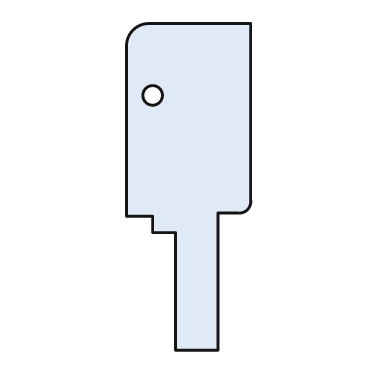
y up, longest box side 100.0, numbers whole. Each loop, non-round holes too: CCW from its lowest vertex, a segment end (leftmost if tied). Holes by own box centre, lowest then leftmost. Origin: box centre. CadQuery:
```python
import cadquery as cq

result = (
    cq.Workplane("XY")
    .moveTo(-4.0, -50.0)
    .lineTo(9.0, -50.0)
    .lineTo(9.0, -8.0)
    .lineTo(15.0, -8.0)
    .threePointArc((18.0, -7.0), (19.0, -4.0))
    .lineTo(19.0, 50.0)
    .lineTo(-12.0, 50.0)
    .threePointArc((-17.0, 48.0), (-19.0, 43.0))
    .lineTo(-19.0, -9.0)
    .lineTo(-11.0, -9.0)
    .lineTo(-11.0, -14.0)
    .lineTo(-4.0, -14.0)
    .close()
    .moveTo(-11.0, 28.0)
    .circle(3.0)
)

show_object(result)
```